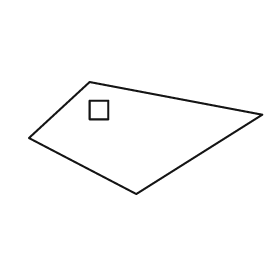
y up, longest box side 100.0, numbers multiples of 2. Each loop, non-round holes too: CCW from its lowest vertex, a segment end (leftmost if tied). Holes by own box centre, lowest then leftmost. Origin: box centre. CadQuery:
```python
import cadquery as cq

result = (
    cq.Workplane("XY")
    .moveTo(-4.0, -24.0)
    .lineTo(50.0, 10.0)
    .lineTo(-24.0, 24.0)
    .lineTo(-50.0, 0.0)
    .close()
    .moveTo(-24.0, 8.0)
    .lineTo(-16.0, 8.0)
    .lineTo(-16.0, 16.0)
    .lineTo(-24.0, 16.0)
    .close()
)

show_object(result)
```